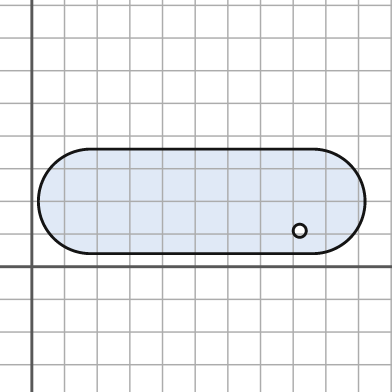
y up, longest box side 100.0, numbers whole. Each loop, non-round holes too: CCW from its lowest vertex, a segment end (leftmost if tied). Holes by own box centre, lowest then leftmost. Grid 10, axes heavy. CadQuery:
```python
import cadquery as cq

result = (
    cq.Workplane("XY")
    .moveTo(18.0, 4.0)
    .lineTo(86.0, 4.0)
    .threePointArc((102.0, 20.0), (86.0, 36.0))
    .lineTo(18.0, 36.0)
    .threePointArc((2.0, 20.0), (18.0, 4.0))
    .close()
    .moveTo(82.0, 11.0)
    .circle(2.0)
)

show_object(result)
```